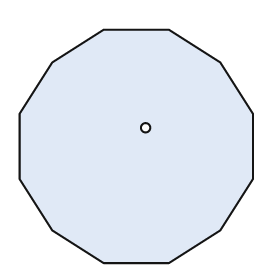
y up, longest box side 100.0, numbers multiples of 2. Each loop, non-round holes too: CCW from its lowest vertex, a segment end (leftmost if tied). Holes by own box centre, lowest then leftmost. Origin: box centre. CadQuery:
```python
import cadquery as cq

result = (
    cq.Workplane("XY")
    .moveTo(-14.0, -50.0)
    .lineTo(14.0, -50.0)
    .lineTo(36.0, -36.0)
    .lineTo(50.0, -14.0)
    .lineTo(50.0, 14.0)
    .lineTo(36.0, 36.0)
    .lineTo(14.0, 50.0)
    .lineTo(-14.0, 50.0)
    .lineTo(-36.0, 36.0)
    .lineTo(-50.0, 14.0)
    .lineTo(-50.0, -14.0)
    .lineTo(-36.0, -36.0)
    .close()
    .moveTo(4.0, 8.0)
    .circle(2.0)
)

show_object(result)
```